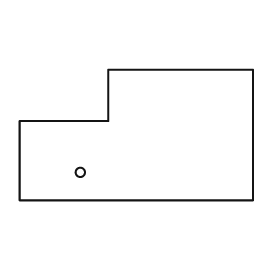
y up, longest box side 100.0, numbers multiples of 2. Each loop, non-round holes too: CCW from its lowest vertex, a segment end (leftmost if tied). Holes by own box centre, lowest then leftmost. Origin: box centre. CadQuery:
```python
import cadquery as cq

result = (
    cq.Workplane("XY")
    .moveTo(-50.0, -28.0)
    .lineTo(50.0, -28.0)
    .lineTo(50.0, 28.0)
    .lineTo(-12.0, 28.0)
    .lineTo(-12.0, 6.0)
    .lineTo(-50.0, 6.0)
    .close()
    .moveTo(-24.0, -16.0)
    .circle(2.0)
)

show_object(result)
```